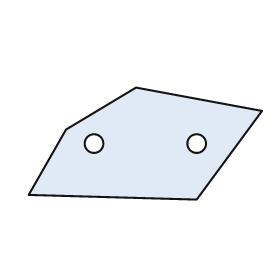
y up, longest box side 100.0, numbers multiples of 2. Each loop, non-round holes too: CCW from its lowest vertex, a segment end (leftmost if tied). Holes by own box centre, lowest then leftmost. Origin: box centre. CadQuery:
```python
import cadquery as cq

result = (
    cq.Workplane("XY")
    .moveTo(22.0, -24.0)
    .lineTo(50.0, 14.0)
    .lineTo(-4.0, 24.0)
    .lineTo(-34.0, 6.0)
    .lineTo(-50.0, -22.0)
    .close()
    .moveTo(-22.0, 0.0)
    .circle(4.0)
    .moveTo(22.0, 0.0)
    .circle(4.0)
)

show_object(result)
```